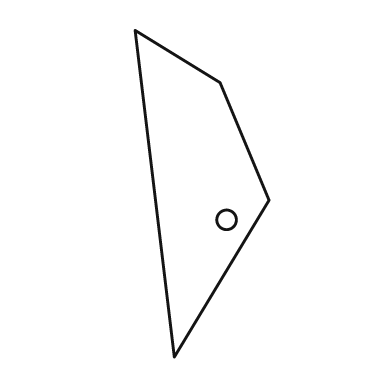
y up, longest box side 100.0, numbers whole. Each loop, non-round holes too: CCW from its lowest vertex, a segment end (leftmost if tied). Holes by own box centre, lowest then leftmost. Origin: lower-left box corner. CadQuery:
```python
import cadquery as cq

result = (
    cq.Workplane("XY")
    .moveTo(12.0, 0.0)
    .lineTo(41.0, 48.0)
    .lineTo(26.0, 84.0)
    .lineTo(0.0, 100.0)
    .close()
    .moveTo(28.0, 42.0)
    .circle(3.0)
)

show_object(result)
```